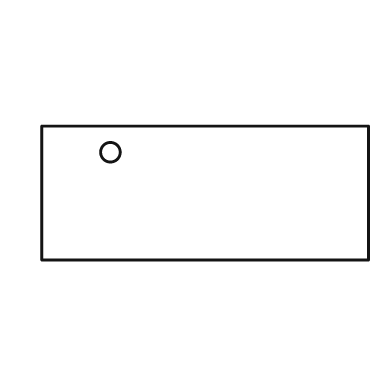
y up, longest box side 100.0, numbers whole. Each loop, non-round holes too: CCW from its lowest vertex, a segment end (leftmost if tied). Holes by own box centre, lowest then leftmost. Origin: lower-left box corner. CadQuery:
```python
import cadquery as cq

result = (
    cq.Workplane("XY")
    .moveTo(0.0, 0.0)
    .lineTo(100.0, 0.0)
    .lineTo(100.0, 41.0)
    .lineTo(0.0, 41.0)
    .close()
    .moveTo(21.0, 33.0)
    .circle(3.0)
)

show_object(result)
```